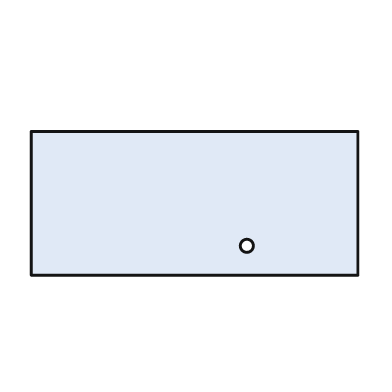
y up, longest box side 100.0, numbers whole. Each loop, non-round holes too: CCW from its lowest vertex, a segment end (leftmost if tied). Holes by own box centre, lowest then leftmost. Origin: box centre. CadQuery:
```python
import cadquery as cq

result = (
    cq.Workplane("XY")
    .moveTo(-50.0, -22.0)
    .lineTo(50.0, -22.0)
    .lineTo(50.0, 22.0)
    .lineTo(-50.0, 22.0)
    .close()
    .moveTo(16.0, -13.0)
    .circle(2.0)
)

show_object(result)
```